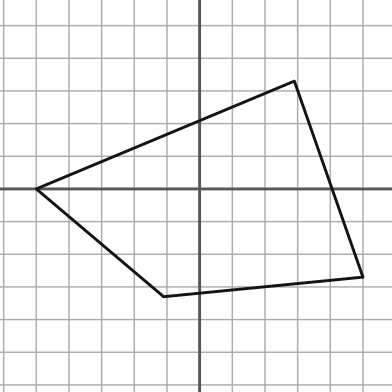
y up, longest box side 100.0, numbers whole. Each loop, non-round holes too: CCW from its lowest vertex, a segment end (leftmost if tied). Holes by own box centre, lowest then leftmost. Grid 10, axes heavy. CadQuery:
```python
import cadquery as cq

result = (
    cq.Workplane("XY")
    .moveTo(-11.0, -33.0)
    .lineTo(50.0, -27.0)
    .lineTo(29.0, 33.0)
    .lineTo(-50.0, 0.0)
    .close()
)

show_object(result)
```